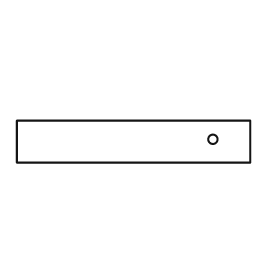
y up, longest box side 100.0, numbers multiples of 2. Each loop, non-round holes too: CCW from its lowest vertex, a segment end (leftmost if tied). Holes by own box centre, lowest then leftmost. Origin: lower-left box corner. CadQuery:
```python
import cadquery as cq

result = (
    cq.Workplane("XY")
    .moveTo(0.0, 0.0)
    .lineTo(100.0, 0.0)
    .lineTo(100.0, 18.0)
    .lineTo(0.0, 18.0)
    .close()
    .moveTo(84.0, 10.0)
    .circle(2.0)
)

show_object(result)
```